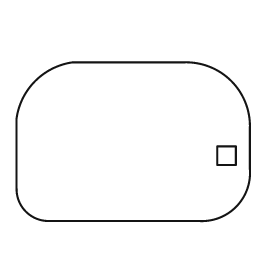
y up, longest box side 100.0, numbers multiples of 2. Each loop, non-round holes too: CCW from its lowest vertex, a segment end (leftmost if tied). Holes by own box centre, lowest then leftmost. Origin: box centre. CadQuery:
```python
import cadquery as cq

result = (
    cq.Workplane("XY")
    .moveTo(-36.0, -34.0)
    .lineTo(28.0, -34.0)
    .threePointArc((44.0, -28.0), (50.0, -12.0))
    .lineTo(50.0, 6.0)
    .threePointArc((42.0, 26.0), (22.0, 34.0))
    .lineTo(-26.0, 34.0)
    .threePointArc((-42.0, 26.0), (-50.0, 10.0))
    .lineTo(-50.0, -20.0)
    .threePointArc((-46.0, -30.0), (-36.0, -34.0))
    .close()
    .moveTo(36.0, -10.0)
    .lineTo(44.0, -10.0)
    .lineTo(44.0, -2.0)
    .lineTo(36.0, -2.0)
    .close()
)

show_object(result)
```